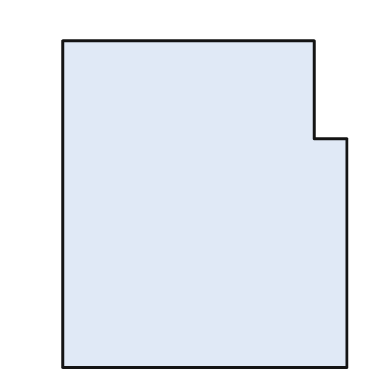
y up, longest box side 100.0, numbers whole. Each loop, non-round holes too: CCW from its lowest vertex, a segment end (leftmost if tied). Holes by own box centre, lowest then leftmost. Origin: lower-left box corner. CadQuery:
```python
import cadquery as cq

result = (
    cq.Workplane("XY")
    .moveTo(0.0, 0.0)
    .lineTo(87.0, 0.0)
    .lineTo(87.0, 70.0)
    .lineTo(77.0, 70.0)
    .lineTo(77.0, 100.0)
    .lineTo(0.0, 100.0)
    .close()
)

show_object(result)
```